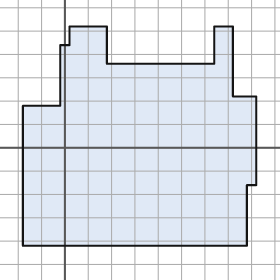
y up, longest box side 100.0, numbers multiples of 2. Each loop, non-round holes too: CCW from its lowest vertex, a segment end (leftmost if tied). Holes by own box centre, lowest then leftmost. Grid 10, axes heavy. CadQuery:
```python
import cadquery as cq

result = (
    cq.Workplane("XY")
    .moveTo(-18.0, -42.0)
    .lineTo(78.0, -42.0)
    .lineTo(78.0, -16.0)
    .lineTo(82.0, -16.0)
    .lineTo(82.0, 22.0)
    .lineTo(72.0, 22.0)
    .lineTo(72.0, 52.0)
    .lineTo(64.0, 52.0)
    .lineTo(64.0, 36.0)
    .lineTo(18.0, 36.0)
    .lineTo(18.0, 52.0)
    .lineTo(2.0, 52.0)
    .lineTo(2.0, 44.0)
    .lineTo(-2.0, 44.0)
    .lineTo(-2.0, 18.0)
    .lineTo(-18.0, 18.0)
    .close()
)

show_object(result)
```